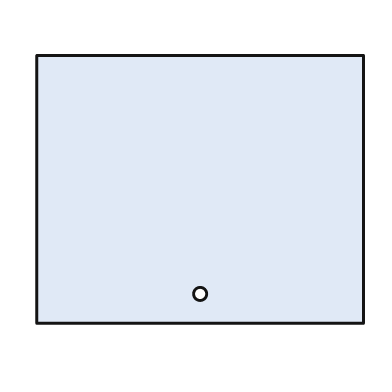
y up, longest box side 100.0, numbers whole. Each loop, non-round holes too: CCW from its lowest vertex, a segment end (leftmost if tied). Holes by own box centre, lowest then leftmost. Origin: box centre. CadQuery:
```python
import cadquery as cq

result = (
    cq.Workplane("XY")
    .moveTo(-50.0, -41.0)
    .lineTo(50.0, -41.0)
    .lineTo(50.0, 41.0)
    .lineTo(-50.0, 41.0)
    .close()
    .moveTo(0.0, -32.0)
    .circle(2.0)
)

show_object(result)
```